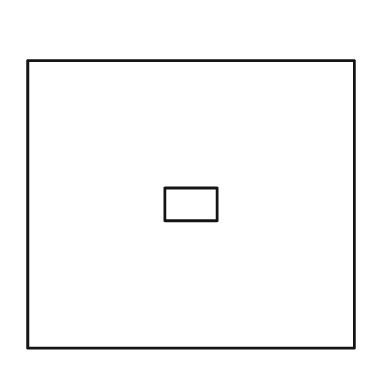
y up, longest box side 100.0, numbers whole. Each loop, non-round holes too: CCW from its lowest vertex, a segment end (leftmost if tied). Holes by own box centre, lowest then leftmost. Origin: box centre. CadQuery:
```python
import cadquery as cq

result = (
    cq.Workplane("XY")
    .moveTo(-50.0, -44.0)
    .lineTo(50.0, -44.0)
    .lineTo(50.0, 44.0)
    .lineTo(-50.0, 44.0)
    .close()
    .moveTo(-8.0, -5.0)
    .lineTo(8.0, -5.0)
    .lineTo(8.0, 5.0)
    .lineTo(-8.0, 5.0)
    .close()
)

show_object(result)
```